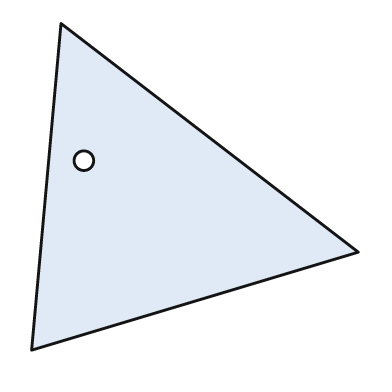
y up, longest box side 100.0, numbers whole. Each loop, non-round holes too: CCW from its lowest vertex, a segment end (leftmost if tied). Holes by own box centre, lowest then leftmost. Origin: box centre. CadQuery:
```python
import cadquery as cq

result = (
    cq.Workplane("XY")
    .moveTo(-50.0, -50.0)
    .lineTo(50.0, -20.0)
    .lineTo(-41.0, 50.0)
    .close()
    .moveTo(-34.0, 8.0)
    .circle(3.0)
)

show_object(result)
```